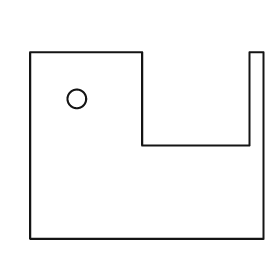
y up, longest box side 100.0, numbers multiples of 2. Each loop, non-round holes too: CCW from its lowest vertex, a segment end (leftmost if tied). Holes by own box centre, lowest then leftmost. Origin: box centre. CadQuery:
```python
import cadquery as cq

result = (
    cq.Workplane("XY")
    .moveTo(-50.0, -40.0)
    .lineTo(50.0, -40.0)
    .lineTo(50.0, 40.0)
    .lineTo(44.0, 40.0)
    .lineTo(44.0, 0.0)
    .lineTo(-2.0, 0.0)
    .lineTo(-2.0, 40.0)
    .lineTo(-50.0, 40.0)
    .close()
    .moveTo(-30.0, 20.0)
    .circle(4.0)
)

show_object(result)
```